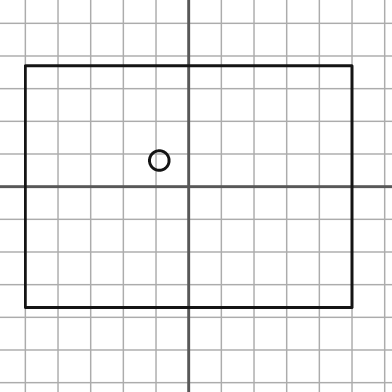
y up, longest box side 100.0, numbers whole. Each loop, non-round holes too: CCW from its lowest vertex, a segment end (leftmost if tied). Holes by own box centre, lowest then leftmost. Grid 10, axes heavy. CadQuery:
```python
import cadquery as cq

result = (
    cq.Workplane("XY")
    .moveTo(-50.0, -37.0)
    .lineTo(50.0, -37.0)
    .lineTo(50.0, 37.0)
    .lineTo(-50.0, 37.0)
    .close()
    .moveTo(-9.0, 8.0)
    .circle(3.0)
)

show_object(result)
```